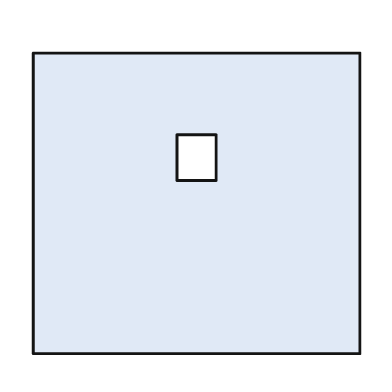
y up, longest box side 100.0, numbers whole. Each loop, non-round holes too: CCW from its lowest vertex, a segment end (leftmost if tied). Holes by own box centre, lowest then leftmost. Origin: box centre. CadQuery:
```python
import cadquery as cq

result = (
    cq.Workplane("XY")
    .moveTo(-50.0, -46.0)
    .lineTo(50.0, -46.0)
    .lineTo(50.0, 46.0)
    .lineTo(-50.0, 46.0)
    .close()
    .moveTo(-6.0, 7.0)
    .lineTo(6.0, 7.0)
    .lineTo(6.0, 21.0)
    .lineTo(-6.0, 21.0)
    .close()
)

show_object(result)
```